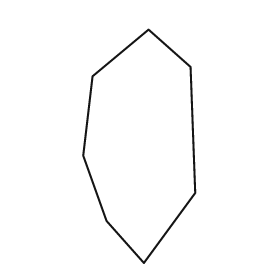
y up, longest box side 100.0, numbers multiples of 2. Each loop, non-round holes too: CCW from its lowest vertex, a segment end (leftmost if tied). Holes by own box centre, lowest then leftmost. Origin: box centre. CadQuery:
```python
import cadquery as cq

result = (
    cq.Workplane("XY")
    .moveTo(2.0, -50.0)
    .lineTo(24.0, -20.0)
    .lineTo(22.0, 34.0)
    .lineTo(4.0, 50.0)
    .lineTo(-20.0, 30.0)
    .lineTo(-24.0, -4.0)
    .lineTo(-14.0, -32.0)
    .close()
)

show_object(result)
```